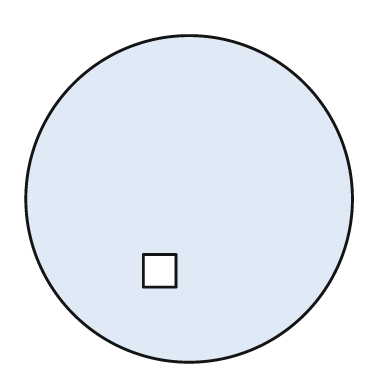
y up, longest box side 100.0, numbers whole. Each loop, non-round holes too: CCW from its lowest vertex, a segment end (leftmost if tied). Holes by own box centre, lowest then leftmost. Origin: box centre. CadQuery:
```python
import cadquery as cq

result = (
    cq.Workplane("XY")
    .moveTo(0.0, 0.0)
    .circle(50.0)
    .moveTo(-14.0, -27.0)
    .lineTo(-4.0, -27.0)
    .lineTo(-4.0, -17.0)
    .lineTo(-14.0, -17.0)
    .close()
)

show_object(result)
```